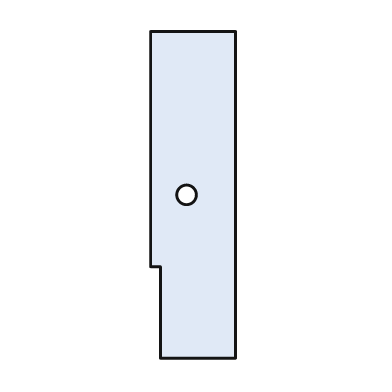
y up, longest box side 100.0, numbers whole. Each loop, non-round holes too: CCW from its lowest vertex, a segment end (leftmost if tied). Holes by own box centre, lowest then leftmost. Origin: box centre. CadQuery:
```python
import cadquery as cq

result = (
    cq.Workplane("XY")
    .moveTo(-10.0, -50.0)
    .lineTo(13.0, -50.0)
    .lineTo(13.0, 50.0)
    .lineTo(-13.0, 50.0)
    .lineTo(-13.0, -22.0)
    .lineTo(-10.0, -22.0)
    .close()
    .moveTo(-2.0, 0.0)
    .circle(3.0)
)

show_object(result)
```